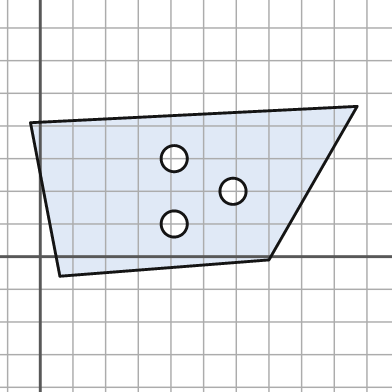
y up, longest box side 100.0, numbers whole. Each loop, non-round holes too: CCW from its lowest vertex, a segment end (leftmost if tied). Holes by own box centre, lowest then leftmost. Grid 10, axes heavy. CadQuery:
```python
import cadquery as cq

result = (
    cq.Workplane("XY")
    .moveTo(6.0, -6.0)
    .lineTo(70.0, -1.0)
    .lineTo(97.0, 46.0)
    .lineTo(-3.0, 41.0)
    .close()
    .moveTo(41.0, 10.0)
    .circle(4.0)
    .moveTo(59.0, 20.0)
    .circle(4.0)
    .moveTo(41.0, 30.0)
    .circle(4.0)
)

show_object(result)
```